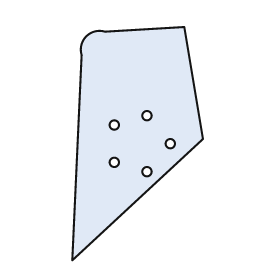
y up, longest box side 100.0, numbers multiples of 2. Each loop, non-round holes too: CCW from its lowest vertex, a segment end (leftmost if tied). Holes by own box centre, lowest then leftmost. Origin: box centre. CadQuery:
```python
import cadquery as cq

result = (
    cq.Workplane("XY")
    .moveTo(-28.0, -50.0)
    .lineTo(28.0, 2.0)
    .lineTo(20.0, 50.0)
    .lineTo(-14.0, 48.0)
    .threePointArc((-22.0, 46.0), (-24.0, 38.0))
    .close()
    .moveTo(4.0, -12.0)
    .circle(2.0)
    .moveTo(-10.0, -8.0)
    .circle(2.0)
    .moveTo(14.0, 0.0)
    .circle(2.0)
    .moveTo(-10.0, 8.0)
    .circle(2.0)
    .moveTo(4.0, 12.0)
    .circle(2.0)
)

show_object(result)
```